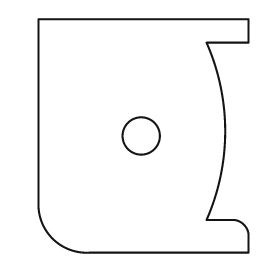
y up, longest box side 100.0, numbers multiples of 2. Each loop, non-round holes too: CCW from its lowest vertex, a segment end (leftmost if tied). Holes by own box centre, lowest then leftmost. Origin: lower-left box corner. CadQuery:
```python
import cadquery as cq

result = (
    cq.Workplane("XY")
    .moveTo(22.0, 0.0)
    .lineTo(90.0, 0.0)
    .lineTo(90.0, 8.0)
    .threePointArc((88.0, 12.0), (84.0, 14.0))
    .lineTo(72.0, 14.0)
    .threePointArc((80.0, 52.0), (72.0, 90.0))
    .lineTo(90.0, 90.0)
    .lineTo(90.0, 100.0)
    .lineTo(0.0, 100.0)
    .lineTo(0.0, 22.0)
    .threePointArc((6.0, 6.0), (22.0, 0.0))
    .close()
    .moveTo(44.0, 50.0)
    .circle(8.0)
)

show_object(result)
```